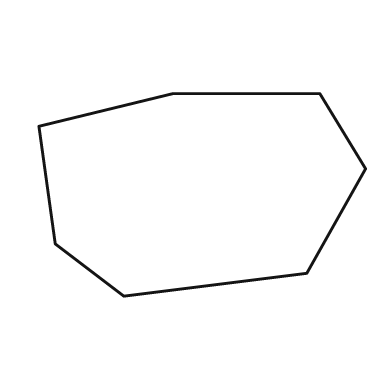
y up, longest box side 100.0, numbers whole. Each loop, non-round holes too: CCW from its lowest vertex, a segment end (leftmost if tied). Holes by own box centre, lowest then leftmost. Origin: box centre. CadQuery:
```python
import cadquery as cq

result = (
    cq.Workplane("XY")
    .moveTo(-24.0, -31.0)
    .lineTo(32.0, -24.0)
    .lineTo(50.0, 8.0)
    .lineTo(36.0, 31.0)
    .lineTo(-9.0, 31.0)
    .lineTo(-50.0, 21.0)
    .lineTo(-45.0, -15.0)
    .close()
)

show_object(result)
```